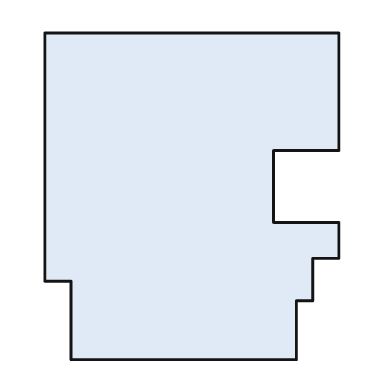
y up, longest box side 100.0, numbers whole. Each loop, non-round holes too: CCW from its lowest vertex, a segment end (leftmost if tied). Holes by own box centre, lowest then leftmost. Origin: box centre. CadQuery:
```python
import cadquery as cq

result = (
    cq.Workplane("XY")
    .moveTo(-37.0, -50.0)
    .lineTo(32.0, -50.0)
    .lineTo(32.0, -32.0)
    .lineTo(37.0, -32.0)
    .lineTo(37.0, -19.0)
    .lineTo(45.0, -19.0)
    .lineTo(45.0, -8.0)
    .lineTo(25.0, -8.0)
    .lineTo(25.0, 14.0)
    .lineTo(45.0, 14.0)
    .lineTo(45.0, 50.0)
    .lineTo(-45.0, 50.0)
    .lineTo(-45.0, -26.0)
    .lineTo(-37.0, -26.0)
    .close()
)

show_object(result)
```